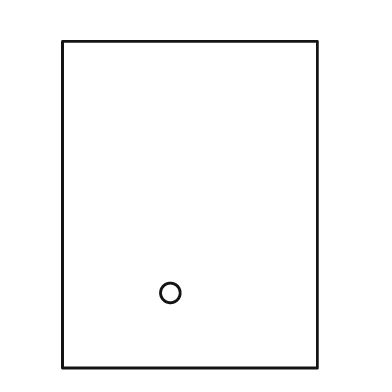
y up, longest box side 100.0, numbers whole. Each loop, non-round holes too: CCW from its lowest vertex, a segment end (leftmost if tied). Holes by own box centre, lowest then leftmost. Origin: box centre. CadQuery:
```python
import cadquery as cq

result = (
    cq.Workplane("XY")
    .moveTo(-39.0, -50.0)
    .lineTo(39.0, -50.0)
    .lineTo(39.0, 50.0)
    .lineTo(-39.0, 50.0)
    .close()
    .moveTo(-6.0, -27.0)
    .circle(3.0)
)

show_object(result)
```